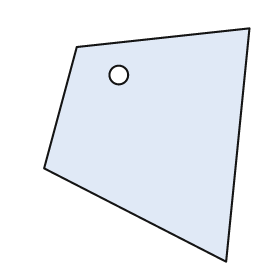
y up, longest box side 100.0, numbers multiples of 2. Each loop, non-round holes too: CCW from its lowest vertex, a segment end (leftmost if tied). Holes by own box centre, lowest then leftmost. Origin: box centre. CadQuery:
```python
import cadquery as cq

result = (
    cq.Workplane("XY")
    .moveTo(34.0, -50.0)
    .lineTo(44.0, 50.0)
    .lineTo(-30.0, 42.0)
    .lineTo(-44.0, -10.0)
    .close()
    .moveTo(-12.0, 30.0)
    .circle(4.0)
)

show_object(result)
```